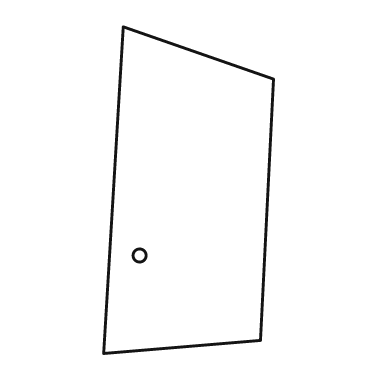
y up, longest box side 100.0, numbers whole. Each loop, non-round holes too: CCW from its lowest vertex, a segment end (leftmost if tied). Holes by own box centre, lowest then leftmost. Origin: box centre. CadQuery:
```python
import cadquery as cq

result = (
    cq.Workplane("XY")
    .moveTo(-26.0, -50.0)
    .lineTo(22.0, -46.0)
    .lineTo(26.0, 34.0)
    .lineTo(-20.0, 50.0)
    .close()
    .moveTo(-15.0, -20.0)
    .circle(2.0)
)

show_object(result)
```